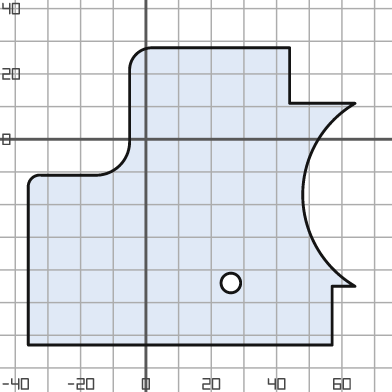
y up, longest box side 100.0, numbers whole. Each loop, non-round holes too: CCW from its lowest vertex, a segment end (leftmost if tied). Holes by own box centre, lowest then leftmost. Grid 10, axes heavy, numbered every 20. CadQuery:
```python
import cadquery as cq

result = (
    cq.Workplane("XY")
    .moveTo(-36.0, -63.0)
    .lineTo(57.0, -63.0)
    .lineTo(57.0, -45.0)
    .lineTo(64.0, -45.0)
    .threePointArc((48.0, -17.0), (64.0, 11.0))
    .lineTo(44.0, 11.0)
    .lineTo(44.0, 28.0)
    .lineTo(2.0, 28.0)
    .threePointArc((-3.0, 26.0), (-5.0, 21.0))
    .lineTo(-5.0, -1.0)
    .threePointArc((-8.0, -8.0), (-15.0, -11.0))
    .lineTo(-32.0, -11.0)
    .threePointArc((-35.0, -12.0), (-36.0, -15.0))
    .close()
    .moveTo(26.0, -44.0)
    .circle(3.0)
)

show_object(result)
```